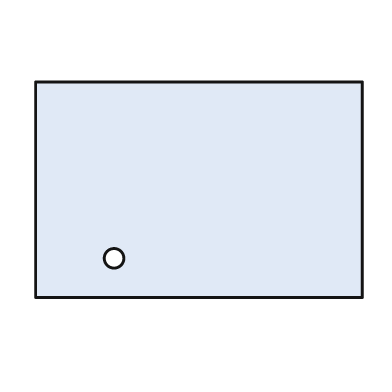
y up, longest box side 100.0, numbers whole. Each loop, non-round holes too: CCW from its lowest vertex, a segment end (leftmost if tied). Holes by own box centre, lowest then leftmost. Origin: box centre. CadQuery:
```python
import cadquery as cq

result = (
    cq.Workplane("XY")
    .moveTo(-50.0, -33.0)
    .lineTo(50.0, -33.0)
    .lineTo(50.0, 33.0)
    .lineTo(-50.0, 33.0)
    .close()
    .moveTo(-26.0, -21.0)
    .circle(3.0)
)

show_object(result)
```